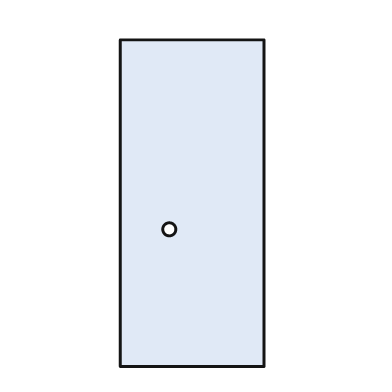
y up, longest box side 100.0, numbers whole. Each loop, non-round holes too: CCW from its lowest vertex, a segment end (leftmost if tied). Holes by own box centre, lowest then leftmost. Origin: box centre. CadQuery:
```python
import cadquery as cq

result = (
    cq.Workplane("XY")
    .moveTo(-22.0, -50.0)
    .lineTo(22.0, -50.0)
    .lineTo(22.0, 50.0)
    .lineTo(-22.0, 50.0)
    .close()
    .moveTo(-7.0, -8.0)
    .circle(2.0)
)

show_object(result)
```